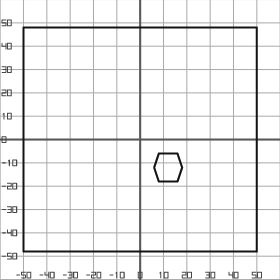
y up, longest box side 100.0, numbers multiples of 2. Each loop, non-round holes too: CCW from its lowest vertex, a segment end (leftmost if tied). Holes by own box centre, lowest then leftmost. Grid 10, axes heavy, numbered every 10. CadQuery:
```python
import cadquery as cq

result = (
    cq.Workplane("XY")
    .moveTo(-50.0, -48.0)
    .lineTo(50.0, -48.0)
    .lineTo(50.0, 48.0)
    .lineTo(-50.0, 48.0)
    .close()
    .moveTo(8.0, -18.0)
    .lineTo(16.0, -18.0)
    .lineTo(18.0, -12.0)
    .lineTo(16.0, -6.0)
    .lineTo(8.0, -6.0)
    .lineTo(6.0, -12.0)
    .close()
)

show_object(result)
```